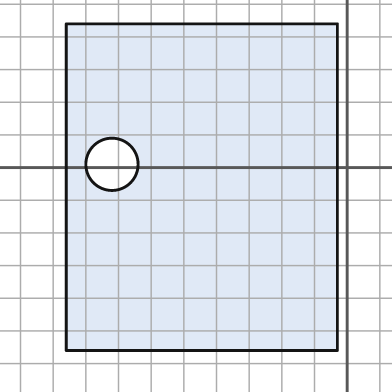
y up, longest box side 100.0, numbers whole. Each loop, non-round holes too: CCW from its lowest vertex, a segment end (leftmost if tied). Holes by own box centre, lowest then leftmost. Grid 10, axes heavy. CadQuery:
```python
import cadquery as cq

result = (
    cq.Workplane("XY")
    .moveTo(-86.0, -56.0)
    .lineTo(-3.0, -56.0)
    .lineTo(-3.0, 44.0)
    .lineTo(-86.0, 44.0)
    .close()
    .moveTo(-72.0, 1.0)
    .circle(8.0)
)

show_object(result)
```